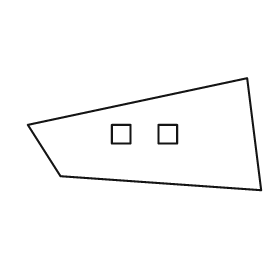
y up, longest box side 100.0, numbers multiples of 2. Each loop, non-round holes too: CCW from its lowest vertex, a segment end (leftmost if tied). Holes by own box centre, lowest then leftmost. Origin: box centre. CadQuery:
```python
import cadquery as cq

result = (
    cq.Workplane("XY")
    .moveTo(50.0, -24.0)
    .lineTo(44.0, 24.0)
    .lineTo(-50.0, 4.0)
    .lineTo(-36.0, -18.0)
    .close()
    .moveTo(-14.0, -4.0)
    .lineTo(-6.0, -4.0)
    .lineTo(-6.0, 4.0)
    .lineTo(-14.0, 4.0)
    .close()
    .moveTo(6.0, -4.0)
    .lineTo(14.0, -4.0)
    .lineTo(14.0, 4.0)
    .lineTo(6.0, 4.0)
    .close()
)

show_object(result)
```